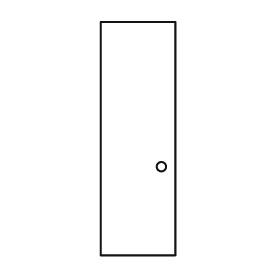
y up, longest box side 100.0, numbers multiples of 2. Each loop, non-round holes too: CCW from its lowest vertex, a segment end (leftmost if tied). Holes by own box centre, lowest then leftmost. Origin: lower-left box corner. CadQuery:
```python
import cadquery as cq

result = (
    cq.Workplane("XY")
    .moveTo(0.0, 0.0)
    .lineTo(32.0, 0.0)
    .lineTo(32.0, 100.0)
    .lineTo(0.0, 100.0)
    .close()
    .moveTo(26.0, 38.0)
    .circle(2.0)
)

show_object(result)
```